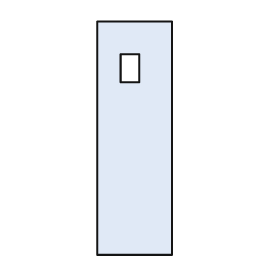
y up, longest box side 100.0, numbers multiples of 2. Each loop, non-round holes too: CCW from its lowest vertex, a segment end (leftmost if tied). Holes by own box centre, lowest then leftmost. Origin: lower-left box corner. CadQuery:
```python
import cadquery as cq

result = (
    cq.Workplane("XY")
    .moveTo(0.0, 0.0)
    .lineTo(32.0, 0.0)
    .lineTo(32.0, 100.0)
    .lineTo(0.0, 100.0)
    .close()
    .moveTo(10.0, 74.0)
    .lineTo(18.0, 74.0)
    .lineTo(18.0, 86.0)
    .lineTo(10.0, 86.0)
    .close()
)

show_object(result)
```